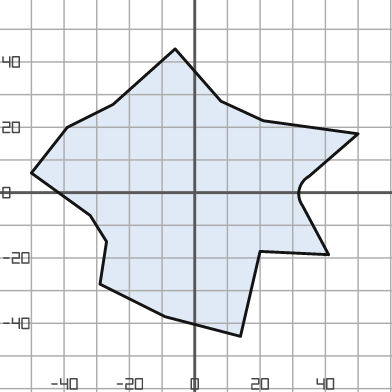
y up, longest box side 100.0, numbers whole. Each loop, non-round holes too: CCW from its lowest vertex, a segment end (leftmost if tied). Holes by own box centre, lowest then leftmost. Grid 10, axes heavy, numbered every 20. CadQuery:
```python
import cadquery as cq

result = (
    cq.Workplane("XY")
    .moveTo(14.0, -44.0)
    .lineTo(20.0, -18.0)
    .lineTo(41.0, -19.0)
    .lineTo(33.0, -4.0)
    .threePointArc((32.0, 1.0), (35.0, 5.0))
    .lineTo(50.0, 18.0)
    .lineTo(21.0, 22.0)
    .lineTo(8.0, 28.0)
    .lineTo(-6.0, 44.0)
    .lineTo(-25.0, 27.0)
    .lineTo(-39.0, 20.0)
    .lineTo(-50.0, 6.0)
    .lineTo(-32.0, -7.0)
    .lineTo(-27.0, -15.0)
    .lineTo(-29.0, -28.0)
    .lineTo(-9.0, -38.0)
    .close()
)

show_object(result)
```